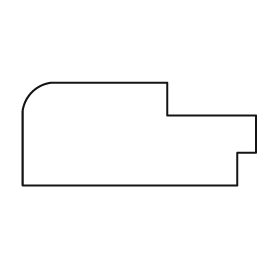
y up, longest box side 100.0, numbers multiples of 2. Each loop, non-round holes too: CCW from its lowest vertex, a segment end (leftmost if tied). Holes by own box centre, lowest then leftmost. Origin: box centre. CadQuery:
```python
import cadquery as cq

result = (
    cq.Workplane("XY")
    .moveTo(-50.0, -22.0)
    .lineTo(42.0, -22.0)
    .lineTo(42.0, -8.0)
    .lineTo(50.0, -8.0)
    .lineTo(50.0, 8.0)
    .lineTo(12.0, 8.0)
    .lineTo(12.0, 22.0)
    .lineTo(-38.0, 22.0)
    .threePointArc((-46.0, 18.0), (-50.0, 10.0))
    .close()
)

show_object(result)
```